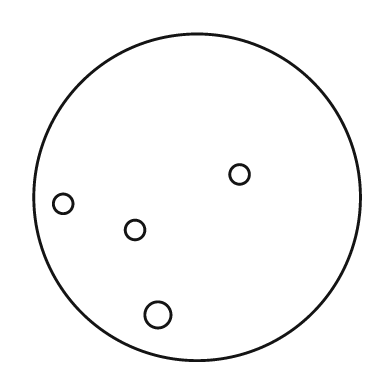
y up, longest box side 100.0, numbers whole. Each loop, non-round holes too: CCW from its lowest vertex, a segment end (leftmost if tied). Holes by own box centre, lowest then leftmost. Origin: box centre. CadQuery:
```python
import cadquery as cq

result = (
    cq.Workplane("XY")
    .moveTo(0.0, 0.0)
    .circle(50.0)
    .moveTo(-12.0, -36.0)
    .circle(4.0)
    .moveTo(-19.0, -10.0)
    .circle(3.0)
    .moveTo(-41.0, -2.0)
    .circle(3.0)
    .moveTo(13.0, 7.0)
    .circle(3.0)
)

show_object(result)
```